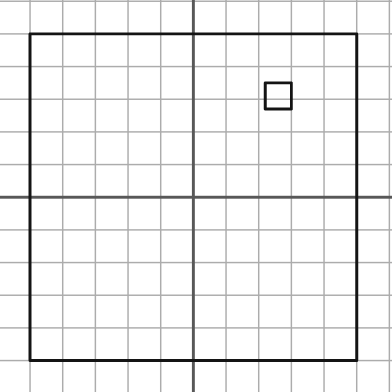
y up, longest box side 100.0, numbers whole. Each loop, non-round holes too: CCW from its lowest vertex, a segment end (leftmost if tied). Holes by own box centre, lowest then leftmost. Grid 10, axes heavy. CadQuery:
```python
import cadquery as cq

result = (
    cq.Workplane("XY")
    .moveTo(-50.0, -50.0)
    .lineTo(50.0, -50.0)
    .lineTo(50.0, 50.0)
    .lineTo(-50.0, 50.0)
    .close()
    .moveTo(22.0, 27.0)
    .lineTo(30.0, 27.0)
    .lineTo(30.0, 35.0)
    .lineTo(22.0, 35.0)
    .close()
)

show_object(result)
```